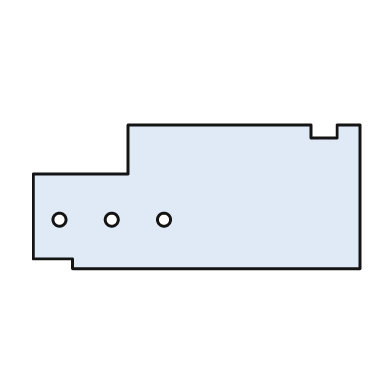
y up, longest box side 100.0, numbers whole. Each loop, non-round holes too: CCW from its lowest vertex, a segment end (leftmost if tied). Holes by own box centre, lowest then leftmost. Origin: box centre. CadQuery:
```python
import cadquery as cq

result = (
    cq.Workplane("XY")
    .moveTo(-38.0, -22.0)
    .lineTo(50.0, -22.0)
    .lineTo(50.0, 22.0)
    .lineTo(43.0, 22.0)
    .lineTo(43.0, 18.0)
    .lineTo(35.0, 18.0)
    .lineTo(35.0, 22.0)
    .lineTo(-21.0, 22.0)
    .lineTo(-21.0, 7.0)
    .lineTo(-50.0, 7.0)
    .lineTo(-50.0, -19.0)
    .lineTo(-38.0, -19.0)
    .close()
    .moveTo(-42.0, -7.0)
    .circle(2.0)
    .moveTo(-26.0, -7.0)
    .circle(2.0)
    .moveTo(-10.0, -7.0)
    .circle(2.0)
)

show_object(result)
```